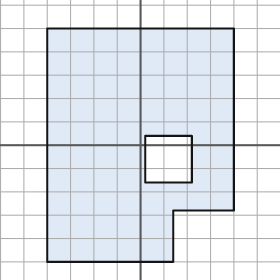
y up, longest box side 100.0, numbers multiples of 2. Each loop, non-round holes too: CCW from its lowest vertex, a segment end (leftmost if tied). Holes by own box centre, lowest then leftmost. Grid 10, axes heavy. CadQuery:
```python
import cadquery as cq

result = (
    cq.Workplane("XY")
    .moveTo(-40.0, -50.0)
    .lineTo(14.0, -50.0)
    .lineTo(14.0, -28.0)
    .lineTo(40.0, -28.0)
    .lineTo(40.0, 50.0)
    .lineTo(-40.0, 50.0)
    .close()
    .moveTo(2.0, -16.0)
    .lineTo(22.0, -16.0)
    .lineTo(22.0, 4.0)
    .lineTo(2.0, 4.0)
    .close()
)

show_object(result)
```